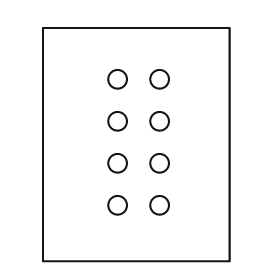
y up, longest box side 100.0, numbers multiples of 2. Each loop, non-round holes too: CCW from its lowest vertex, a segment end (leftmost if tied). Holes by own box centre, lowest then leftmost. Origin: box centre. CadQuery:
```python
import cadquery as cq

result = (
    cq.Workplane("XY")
    .moveTo(-40.0, -50.0)
    .lineTo(40.0, -50.0)
    .lineTo(40.0, 50.0)
    .lineTo(-40.0, 50.0)
    .close()
    .moveTo(-8.0, -26.0)
    .circle(4.0)
    .moveTo(10.0, -26.0)
    .circle(4.0)
    .moveTo(-8.0, -8.0)
    .circle(4.0)
    .moveTo(10.0, -8.0)
    .circle(4.0)
    .moveTo(-8.0, 10.0)
    .circle(4.0)
    .moveTo(10.0, 10.0)
    .circle(4.0)
    .moveTo(-8.0, 28.0)
    .circle(4.0)
    .moveTo(10.0, 28.0)
    .circle(4.0)
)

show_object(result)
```